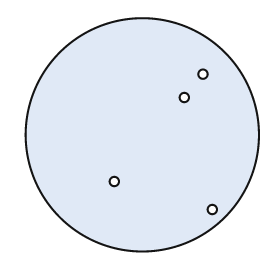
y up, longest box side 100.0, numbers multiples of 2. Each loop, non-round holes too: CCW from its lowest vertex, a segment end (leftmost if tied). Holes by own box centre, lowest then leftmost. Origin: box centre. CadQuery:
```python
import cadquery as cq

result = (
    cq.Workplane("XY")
    .moveTo(0.0, 0.0)
    .circle(50.0)
    .moveTo(30.0, -32.0)
    .circle(2.0)
    .moveTo(-12.0, -20.0)
    .circle(2.0)
    .moveTo(18.0, 16.0)
    .circle(2.0)
    .moveTo(26.0, 26.0)
    .circle(2.0)
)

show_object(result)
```